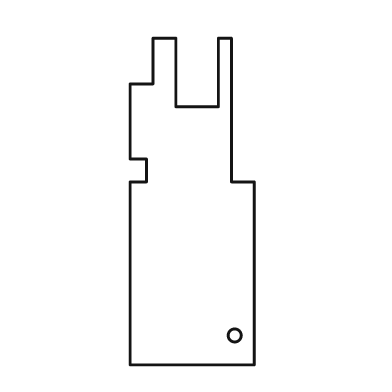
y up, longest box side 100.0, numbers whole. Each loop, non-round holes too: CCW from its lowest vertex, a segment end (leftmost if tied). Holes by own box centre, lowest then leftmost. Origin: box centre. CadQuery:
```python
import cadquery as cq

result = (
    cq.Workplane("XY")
    .moveTo(-19.0, -50.0)
    .lineTo(19.0, -50.0)
    .lineTo(19.0, 6.0)
    .lineTo(12.0, 6.0)
    .lineTo(12.0, 50.0)
    .lineTo(8.0, 50.0)
    .lineTo(8.0, 29.0)
    .lineTo(-5.0, 29.0)
    .lineTo(-5.0, 50.0)
    .lineTo(-12.0, 50.0)
    .lineTo(-12.0, 36.0)
    .lineTo(-19.0, 36.0)
    .lineTo(-19.0, 13.0)
    .lineTo(-14.0, 13.0)
    .lineTo(-14.0, 6.0)
    .lineTo(-19.0, 6.0)
    .close()
    .moveTo(13.0, -41.0)
    .circle(2.0)
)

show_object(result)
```